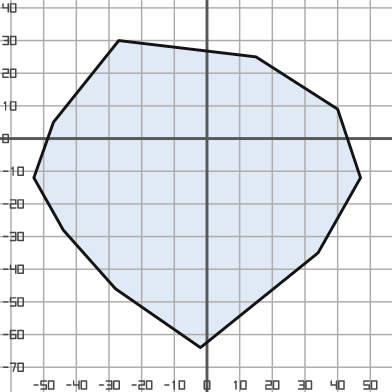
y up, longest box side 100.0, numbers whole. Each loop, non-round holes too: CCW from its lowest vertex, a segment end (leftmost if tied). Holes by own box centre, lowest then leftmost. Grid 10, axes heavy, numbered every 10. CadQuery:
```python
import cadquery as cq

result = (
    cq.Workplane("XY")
    .moveTo(-2.0, -64.0)
    .lineTo(34.0, -35.0)
    .lineTo(47.0, -12.0)
    .lineTo(40.0, 9.0)
    .lineTo(15.0, 25.0)
    .lineTo(-27.0, 30.0)
    .lineTo(-47.0, 5.0)
    .lineTo(-53.0, -12.0)
    .lineTo(-44.0, -28.0)
    .lineTo(-28.0, -46.0)
    .close()
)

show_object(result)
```